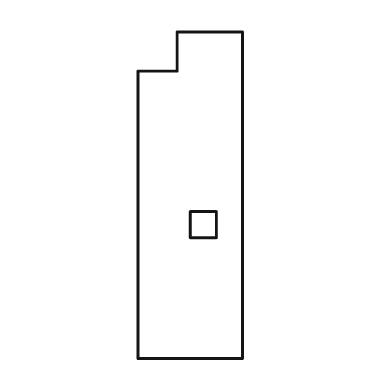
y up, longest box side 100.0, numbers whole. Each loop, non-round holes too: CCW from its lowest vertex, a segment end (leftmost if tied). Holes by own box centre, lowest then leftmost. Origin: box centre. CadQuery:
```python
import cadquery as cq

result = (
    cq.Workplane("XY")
    .moveTo(-16.0, -50.0)
    .lineTo(16.0, -50.0)
    .lineTo(16.0, 50.0)
    .lineTo(-4.0, 50.0)
    .lineTo(-4.0, 38.0)
    .lineTo(-16.0, 38.0)
    .close()
    .moveTo(0.0, -13.0)
    .lineTo(8.0, -13.0)
    .lineTo(8.0, -5.0)
    .lineTo(0.0, -5.0)
    .close()
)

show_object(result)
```